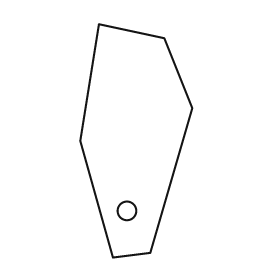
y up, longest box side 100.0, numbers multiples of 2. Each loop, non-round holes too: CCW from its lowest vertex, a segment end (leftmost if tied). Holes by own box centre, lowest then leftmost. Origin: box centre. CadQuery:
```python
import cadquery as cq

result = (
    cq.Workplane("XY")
    .moveTo(-10.0, -50.0)
    .lineTo(6.0, -48.0)
    .lineTo(24.0, 14.0)
    .lineTo(12.0, 44.0)
    .lineTo(-16.0, 50.0)
    .lineTo(-24.0, 0.0)
    .close()
    .moveTo(-4.0, -30.0)
    .circle(4.0)
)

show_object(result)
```